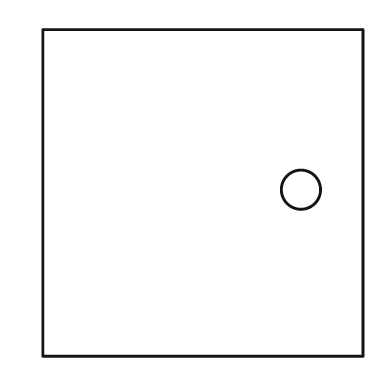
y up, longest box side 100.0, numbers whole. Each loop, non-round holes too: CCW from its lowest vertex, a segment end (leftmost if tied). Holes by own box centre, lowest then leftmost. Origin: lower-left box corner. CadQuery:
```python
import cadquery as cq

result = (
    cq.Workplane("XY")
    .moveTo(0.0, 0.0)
    .lineTo(98.0, 0.0)
    .lineTo(98.0, 100.0)
    .lineTo(0.0, 100.0)
    .close()
    .moveTo(79.0, 51.0)
    .circle(6.0)
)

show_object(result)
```